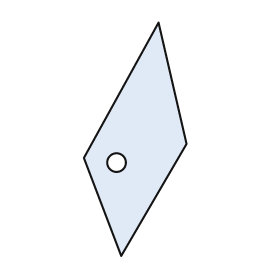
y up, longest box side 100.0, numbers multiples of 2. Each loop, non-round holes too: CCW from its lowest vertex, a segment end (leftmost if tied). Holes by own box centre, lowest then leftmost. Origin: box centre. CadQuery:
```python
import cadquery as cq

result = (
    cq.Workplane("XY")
    .moveTo(-6.0, -50.0)
    .lineTo(22.0, -2.0)
    .lineTo(10.0, 50.0)
    .lineTo(-22.0, -8.0)
    .close()
    .moveTo(-8.0, -10.0)
    .circle(4.0)
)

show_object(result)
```